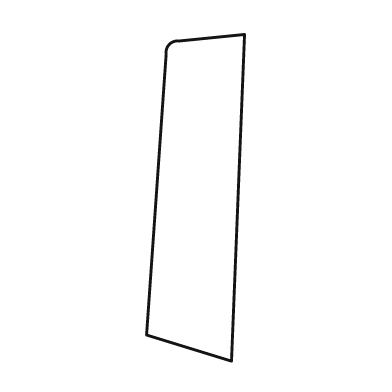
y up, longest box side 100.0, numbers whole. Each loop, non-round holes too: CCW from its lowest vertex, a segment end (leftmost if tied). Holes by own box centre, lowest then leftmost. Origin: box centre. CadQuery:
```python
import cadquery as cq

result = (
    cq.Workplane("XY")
    .moveTo(11.0, -50.0)
    .lineTo(15.0, 50.0)
    .lineTo(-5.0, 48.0)
    .threePointArc((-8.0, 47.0), (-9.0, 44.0))
    .lineTo(-15.0, -42.0)
    .close()
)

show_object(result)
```